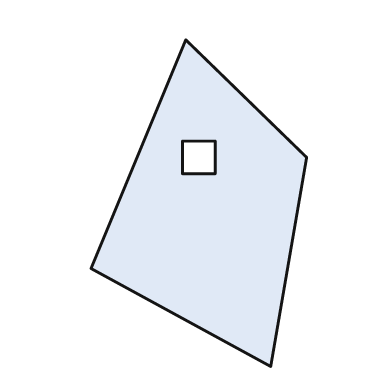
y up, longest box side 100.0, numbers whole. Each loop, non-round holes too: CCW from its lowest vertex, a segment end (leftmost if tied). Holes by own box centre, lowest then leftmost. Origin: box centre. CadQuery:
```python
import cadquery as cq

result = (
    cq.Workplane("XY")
    .moveTo(22.0, -50.0)
    .lineTo(33.0, 14.0)
    .lineTo(-4.0, 50.0)
    .lineTo(-33.0, -20.0)
    .close()
    .moveTo(-5.0, 9.0)
    .lineTo(5.0, 9.0)
    .lineTo(5.0, 19.0)
    .lineTo(-5.0, 19.0)
    .close()
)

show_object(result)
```